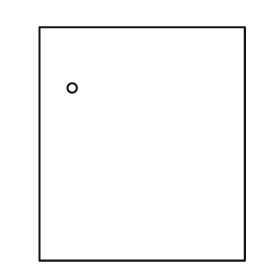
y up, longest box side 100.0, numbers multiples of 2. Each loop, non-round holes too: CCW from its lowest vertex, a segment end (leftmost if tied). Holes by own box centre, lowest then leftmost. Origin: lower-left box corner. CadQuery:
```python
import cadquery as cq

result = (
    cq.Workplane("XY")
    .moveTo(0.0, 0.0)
    .lineTo(88.0, 0.0)
    .lineTo(88.0, 100.0)
    .lineTo(0.0, 100.0)
    .close()
    .moveTo(14.0, 74.0)
    .circle(2.0)
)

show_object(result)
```